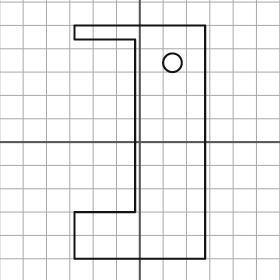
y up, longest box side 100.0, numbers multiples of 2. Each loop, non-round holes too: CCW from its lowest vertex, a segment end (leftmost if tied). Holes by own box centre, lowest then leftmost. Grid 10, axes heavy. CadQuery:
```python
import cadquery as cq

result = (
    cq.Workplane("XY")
    .moveTo(-28.0, -50.0)
    .lineTo(28.0, -50.0)
    .lineTo(28.0, 50.0)
    .lineTo(-28.0, 50.0)
    .lineTo(-28.0, 44.0)
    .lineTo(-2.0, 44.0)
    .lineTo(-2.0, -30.0)
    .lineTo(-28.0, -30.0)
    .close()
    .moveTo(14.0, 34.0)
    .circle(4.0)
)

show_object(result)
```